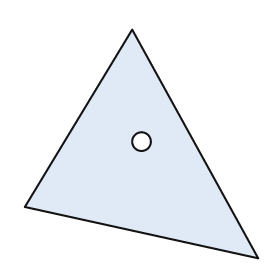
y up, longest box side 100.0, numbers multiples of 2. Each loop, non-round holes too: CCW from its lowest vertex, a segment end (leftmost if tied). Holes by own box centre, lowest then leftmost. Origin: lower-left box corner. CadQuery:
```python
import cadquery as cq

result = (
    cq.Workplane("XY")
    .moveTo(100.0, 0.0)
    .lineTo(46.0, 98.0)
    .lineTo(0.0, 22.0)
    .close()
    .moveTo(50.0, 50.0)
    .circle(4.0)
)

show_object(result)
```